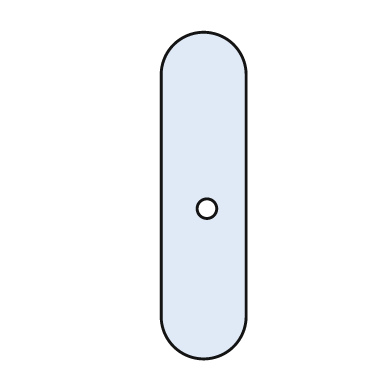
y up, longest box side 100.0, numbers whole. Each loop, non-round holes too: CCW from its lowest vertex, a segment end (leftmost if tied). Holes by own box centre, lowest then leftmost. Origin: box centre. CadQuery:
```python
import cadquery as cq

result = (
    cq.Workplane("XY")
    .moveTo(-13.0, -37.0)
    .threePointArc((0.0, -50.0), (13.0, -37.0))
    .lineTo(13.0, 37.0)
    .threePointArc((0.0, 50.0), (-13.0, 37.0))
    .close()
    .moveTo(1.0, -4.0)
    .circle(3.0)
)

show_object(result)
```